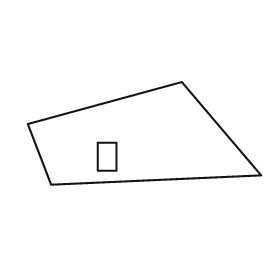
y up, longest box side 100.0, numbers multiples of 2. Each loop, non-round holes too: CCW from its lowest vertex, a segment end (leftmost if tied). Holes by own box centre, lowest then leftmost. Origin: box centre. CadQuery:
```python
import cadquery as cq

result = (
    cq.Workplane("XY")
    .moveTo(-40.0, -22.0)
    .lineTo(50.0, -18.0)
    .lineTo(16.0, 22.0)
    .lineTo(-50.0, 4.0)
    .close()
    .moveTo(-20.0, -16.0)
    .lineTo(-12.0, -16.0)
    .lineTo(-12.0, -4.0)
    .lineTo(-20.0, -4.0)
    .close()
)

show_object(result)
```